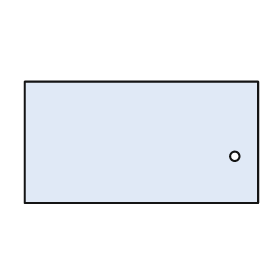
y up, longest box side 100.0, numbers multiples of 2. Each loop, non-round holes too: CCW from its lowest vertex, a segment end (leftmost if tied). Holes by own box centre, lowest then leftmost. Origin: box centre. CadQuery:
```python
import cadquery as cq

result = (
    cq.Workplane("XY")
    .moveTo(-50.0, -26.0)
    .lineTo(50.0, -26.0)
    .lineTo(50.0, 26.0)
    .lineTo(-50.0, 26.0)
    .close()
    .moveTo(40.0, -6.0)
    .circle(2.0)
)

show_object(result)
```